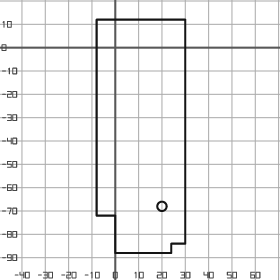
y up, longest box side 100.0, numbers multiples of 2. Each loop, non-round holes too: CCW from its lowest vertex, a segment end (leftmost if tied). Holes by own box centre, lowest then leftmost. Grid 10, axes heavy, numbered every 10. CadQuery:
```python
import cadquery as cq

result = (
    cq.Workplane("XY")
    .moveTo(0.0, -88.0)
    .lineTo(24.0, -88.0)
    .lineTo(24.0, -84.0)
    .lineTo(30.0, -84.0)
    .lineTo(30.0, 12.0)
    .lineTo(-8.0, 12.0)
    .lineTo(-8.0, -72.0)
    .lineTo(0.0, -72.0)
    .close()
    .moveTo(20.0, -68.0)
    .circle(2.0)
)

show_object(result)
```